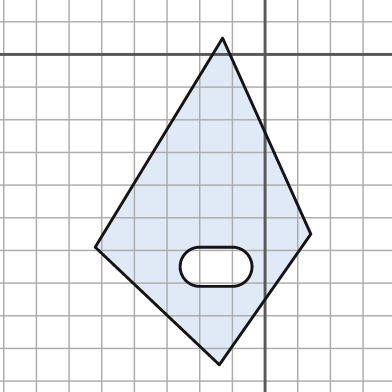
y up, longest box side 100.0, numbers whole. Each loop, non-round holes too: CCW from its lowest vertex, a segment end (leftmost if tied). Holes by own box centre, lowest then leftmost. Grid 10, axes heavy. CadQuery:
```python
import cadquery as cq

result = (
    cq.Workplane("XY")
    .moveTo(-14.0, -95.0)
    .lineTo(14.0, -55.0)
    .lineTo(-13.0, 5.0)
    .lineTo(-52.0, -59.0)
    .close()
    .moveTo(-20.0, -71.0)
    .lineTo(-10.0, -71.0)
    .threePointArc((-4.0, -65.0), (-10.0, -59.0))
    .lineTo(-20.0, -59.0)
    .threePointArc((-26.0, -65.0), (-20.0, -71.0))
    .close()
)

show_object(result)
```